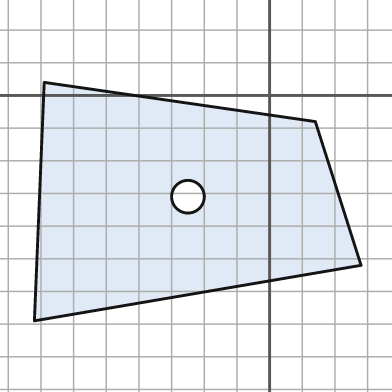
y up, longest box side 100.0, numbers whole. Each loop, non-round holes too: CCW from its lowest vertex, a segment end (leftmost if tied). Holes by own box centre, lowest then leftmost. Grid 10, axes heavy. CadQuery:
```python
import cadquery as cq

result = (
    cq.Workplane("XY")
    .moveTo(-72.0, -69.0)
    .lineTo(28.0, -52.0)
    .lineTo(14.0, -8.0)
    .lineTo(-69.0, 4.0)
    .close()
    .moveTo(-25.0, -31.0)
    .circle(5.0)
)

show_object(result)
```